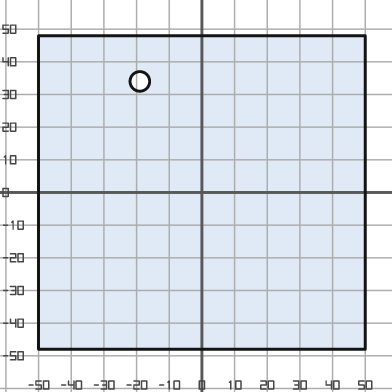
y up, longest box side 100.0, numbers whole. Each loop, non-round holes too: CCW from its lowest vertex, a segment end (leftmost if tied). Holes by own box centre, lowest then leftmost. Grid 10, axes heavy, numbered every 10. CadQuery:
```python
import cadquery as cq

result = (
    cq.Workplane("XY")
    .moveTo(-50.0, -48.0)
    .lineTo(50.0, -48.0)
    .lineTo(50.0, 48.0)
    .lineTo(-50.0, 48.0)
    .close()
    .moveTo(-19.0, 34.0)
    .circle(3.0)
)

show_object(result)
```